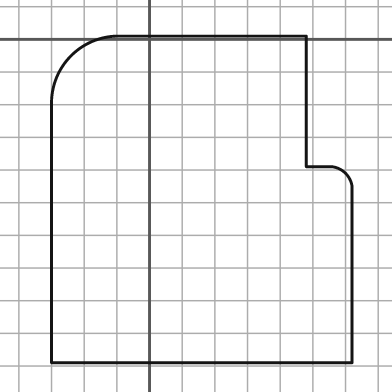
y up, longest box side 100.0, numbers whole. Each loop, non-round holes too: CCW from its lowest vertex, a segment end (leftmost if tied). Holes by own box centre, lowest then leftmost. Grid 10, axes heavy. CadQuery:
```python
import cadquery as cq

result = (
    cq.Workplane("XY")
    .moveTo(-30.0, -99.0)
    .lineTo(62.0, -99.0)
    .lineTo(62.0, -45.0)
    .threePointArc((60.0, -41.0), (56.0, -39.0))
    .lineTo(48.0, -39.0)
    .lineTo(48.0, 1.0)
    .lineTo(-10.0, 1.0)
    .threePointArc((-24.0, -5.0), (-30.0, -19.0))
    .close()
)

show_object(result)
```